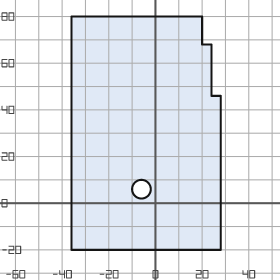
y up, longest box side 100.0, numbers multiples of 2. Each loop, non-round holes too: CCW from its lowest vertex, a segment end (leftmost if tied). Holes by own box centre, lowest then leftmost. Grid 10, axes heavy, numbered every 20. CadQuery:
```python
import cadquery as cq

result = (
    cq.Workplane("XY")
    .moveTo(-36.0, -20.0)
    .lineTo(28.0, -20.0)
    .lineTo(28.0, 46.0)
    .lineTo(24.0, 46.0)
    .lineTo(24.0, 68.0)
    .lineTo(20.0, 68.0)
    .lineTo(20.0, 80.0)
    .lineTo(-36.0, 80.0)
    .close()
    .moveTo(-6.0, 6.0)
    .circle(4.0)
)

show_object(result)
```